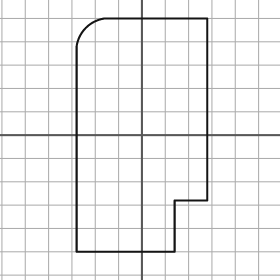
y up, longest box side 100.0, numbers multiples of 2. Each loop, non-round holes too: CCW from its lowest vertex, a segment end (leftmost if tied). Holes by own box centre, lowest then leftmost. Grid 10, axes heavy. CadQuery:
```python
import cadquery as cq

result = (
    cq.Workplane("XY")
    .moveTo(-28.0, -50.0)
    .lineTo(14.0, -50.0)
    .lineTo(14.0, -28.0)
    .lineTo(28.0, -28.0)
    .lineTo(28.0, 50.0)
    .lineTo(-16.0, 50.0)
    .threePointArc((-24.0, 46.0), (-28.0, 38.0))
    .close()
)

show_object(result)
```